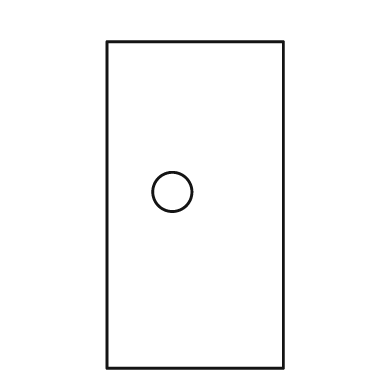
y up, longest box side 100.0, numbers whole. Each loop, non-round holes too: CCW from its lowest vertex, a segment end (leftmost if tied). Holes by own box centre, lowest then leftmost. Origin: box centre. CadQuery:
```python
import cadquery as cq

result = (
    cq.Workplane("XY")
    .moveTo(-27.0, -50.0)
    .lineTo(27.0, -50.0)
    .lineTo(27.0, 50.0)
    .lineTo(-27.0, 50.0)
    .close()
    .moveTo(-7.0, 4.0)
    .circle(6.0)
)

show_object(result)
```